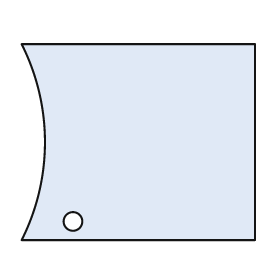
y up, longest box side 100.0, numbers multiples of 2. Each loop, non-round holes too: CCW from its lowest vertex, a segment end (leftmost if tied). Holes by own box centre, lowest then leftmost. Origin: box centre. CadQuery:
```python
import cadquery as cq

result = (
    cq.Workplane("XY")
    .moveTo(-50.0, -42.0)
    .lineTo(50.0, -42.0)
    .lineTo(50.0, 42.0)
    .lineTo(-50.0, 42.0)
    .threePointArc((-40.0, 0.0), (-50.0, -42.0))
    .close()
    .moveTo(-28.0, -34.0)
    .circle(4.0)
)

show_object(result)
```